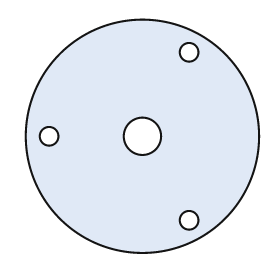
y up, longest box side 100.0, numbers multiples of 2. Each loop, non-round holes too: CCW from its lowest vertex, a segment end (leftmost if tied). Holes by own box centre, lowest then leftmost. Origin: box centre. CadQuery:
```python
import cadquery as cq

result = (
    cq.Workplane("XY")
    .moveTo(0.0, 0.0)
    .circle(50.0)
    .moveTo(20.0, -36.0)
    .circle(4.0)
    .moveTo(-40.0, 0.0)
    .circle(4.0)
    .moveTo(0.0, 0.0)
    .circle(8.0)
    .moveTo(20.0, 36.0)
    .circle(4.0)
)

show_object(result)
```